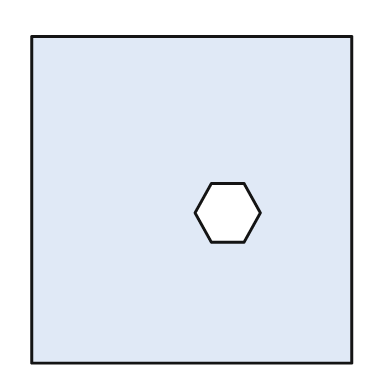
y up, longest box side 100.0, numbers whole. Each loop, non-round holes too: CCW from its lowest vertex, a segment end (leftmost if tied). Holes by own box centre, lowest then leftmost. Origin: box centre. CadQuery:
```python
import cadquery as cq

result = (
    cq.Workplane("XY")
    .moveTo(-49.0, -50.0)
    .lineTo(49.0, -50.0)
    .lineTo(49.0, 50.0)
    .lineTo(-49.0, 50.0)
    .close()
    .moveTo(6.0, -13.0)
    .lineTo(16.0, -13.0)
    .lineTo(21.0, -4.0)
    .lineTo(16.0, 5.0)
    .lineTo(6.0, 5.0)
    .lineTo(1.0, -4.0)
    .close()
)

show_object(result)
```